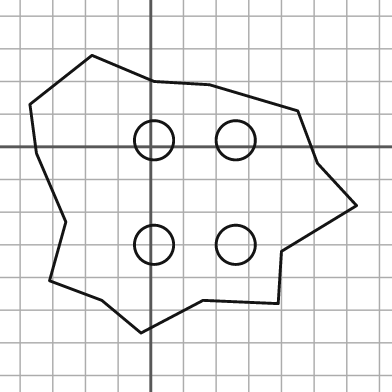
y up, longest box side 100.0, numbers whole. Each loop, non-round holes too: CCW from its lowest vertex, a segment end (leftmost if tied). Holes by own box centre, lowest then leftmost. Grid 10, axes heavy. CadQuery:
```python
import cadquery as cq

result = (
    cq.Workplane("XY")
    .moveTo(-3.0, -57.0)
    .lineTo(16.0, -47.0)
    .lineTo(39.0, -48.0)
    .lineTo(40.0, -32.0)
    .lineTo(63.0, -18.0)
    .lineTo(51.0, -5.0)
    .lineTo(45.0, 11.0)
    .lineTo(18.0, 19.0)
    .lineTo(1.0, 20.0)
    .lineTo(-18.0, 28.0)
    .lineTo(-37.0, 13.0)
    .lineTo(-35.0, -2.0)
    .lineTo(-26.0, -23.0)
    .lineTo(-31.0, -41.0)
    .lineTo(-15.0, -47.0)
    .close()
    .moveTo(1.0, -30.0)
    .circle(6.0)
    .moveTo(26.0, -30.0)
    .circle(6.0)
    .moveTo(1.0, 2.0)
    .circle(6.0)
    .moveTo(26.0, 2.0)
    .circle(6.0)
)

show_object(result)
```